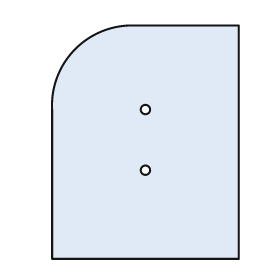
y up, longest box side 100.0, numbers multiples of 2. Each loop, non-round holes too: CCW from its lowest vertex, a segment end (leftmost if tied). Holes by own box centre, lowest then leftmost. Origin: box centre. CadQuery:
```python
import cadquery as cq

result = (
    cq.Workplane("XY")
    .moveTo(-40.0, -50.0)
    .lineTo(40.0, -50.0)
    .lineTo(40.0, 50.0)
    .lineTo(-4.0, 50.0)
    .threePointArc((-30.0, 40.0), (-40.0, 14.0))
    .close()
    .moveTo(0.0, -12.0)
    .circle(2.0)
    .moveTo(0.0, 14.0)
    .circle(2.0)
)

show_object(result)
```